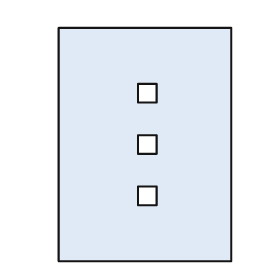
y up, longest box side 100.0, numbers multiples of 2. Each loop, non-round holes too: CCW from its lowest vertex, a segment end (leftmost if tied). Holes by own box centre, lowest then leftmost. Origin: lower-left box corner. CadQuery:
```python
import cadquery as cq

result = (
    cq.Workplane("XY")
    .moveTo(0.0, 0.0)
    .lineTo(74.0, 0.0)
    .lineTo(74.0, 100.0)
    .lineTo(0.0, 100.0)
    .close()
    .moveTo(34.0, 24.0)
    .lineTo(42.0, 24.0)
    .lineTo(42.0, 32.0)
    .lineTo(34.0, 32.0)
    .close()
    .moveTo(34.0, 46.0)
    .lineTo(42.0, 46.0)
    .lineTo(42.0, 54.0)
    .lineTo(34.0, 54.0)
    .close()
    .moveTo(34.0, 68.0)
    .lineTo(42.0, 68.0)
    .lineTo(42.0, 76.0)
    .lineTo(34.0, 76.0)
    .close()
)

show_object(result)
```